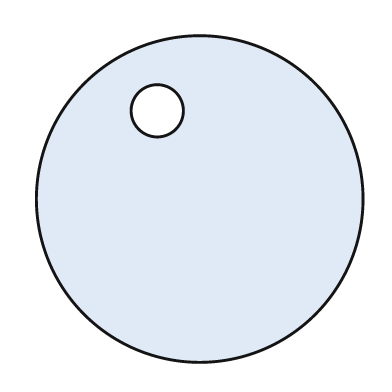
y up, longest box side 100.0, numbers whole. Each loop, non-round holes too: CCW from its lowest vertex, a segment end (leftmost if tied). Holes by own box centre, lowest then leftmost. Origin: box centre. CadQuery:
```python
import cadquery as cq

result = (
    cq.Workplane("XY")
    .moveTo(0.0, 0.0)
    .circle(50.0)
    .moveTo(-13.0, 27.0)
    .circle(8.0)
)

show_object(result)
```